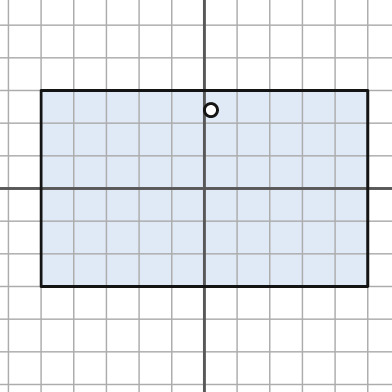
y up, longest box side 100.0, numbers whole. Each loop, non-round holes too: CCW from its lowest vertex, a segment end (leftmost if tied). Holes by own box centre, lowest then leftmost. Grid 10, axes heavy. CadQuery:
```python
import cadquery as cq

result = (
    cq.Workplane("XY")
    .moveTo(-50.0, -30.0)
    .lineTo(50.0, -30.0)
    .lineTo(50.0, 30.0)
    .lineTo(-50.0, 30.0)
    .close()
    .moveTo(2.0, 24.0)
    .circle(2.0)
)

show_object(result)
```